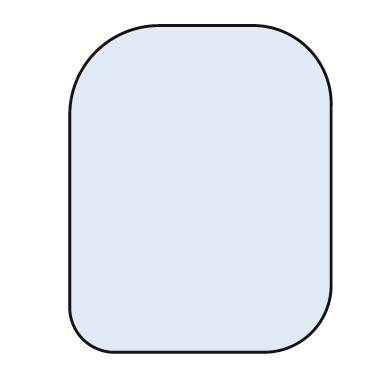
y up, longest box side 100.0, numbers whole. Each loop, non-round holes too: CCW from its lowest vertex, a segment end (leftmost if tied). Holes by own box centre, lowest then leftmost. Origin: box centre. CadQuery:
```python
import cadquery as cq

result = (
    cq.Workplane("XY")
    .moveTo(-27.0, -50.0)
    .lineTo(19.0, -50.0)
    .threePointArc((34.0, -44.0), (40.0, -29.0))
    .lineTo(40.0, 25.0)
    .threePointArc((33.0, 43.0), (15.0, 50.0))
    .lineTo(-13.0, 50.0)
    .threePointArc((-32.0, 42.0), (-40.0, 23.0))
    .lineTo(-40.0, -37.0)
    .threePointArc((-36.0, -46.0), (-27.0, -50.0))
    .close()
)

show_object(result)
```